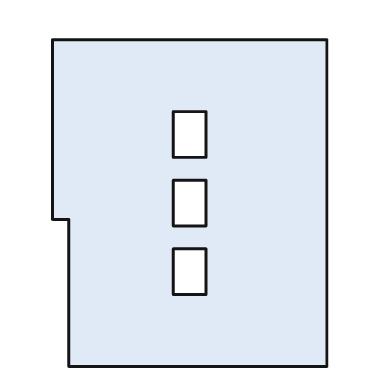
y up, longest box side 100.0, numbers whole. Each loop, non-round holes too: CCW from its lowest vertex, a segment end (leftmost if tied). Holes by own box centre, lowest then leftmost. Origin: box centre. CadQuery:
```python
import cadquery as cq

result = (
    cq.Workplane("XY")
    .moveTo(-37.0, -50.0)
    .lineTo(42.0, -50.0)
    .lineTo(42.0, 50.0)
    .lineTo(-42.0, 50.0)
    .lineTo(-42.0, -5.0)
    .lineTo(-37.0, -5.0)
    .close()
    .moveTo(-5.0, -28.0)
    .lineTo(5.0, -28.0)
    .lineTo(5.0, -14.0)
    .lineTo(-5.0, -14.0)
    .close()
    .moveTo(-5.0, -7.0)
    .lineTo(5.0, -7.0)
    .lineTo(5.0, 7.0)
    .lineTo(-5.0, 7.0)
    .close()
    .moveTo(-5.0, 14.0)
    .lineTo(5.0, 14.0)
    .lineTo(5.0, 28.0)
    .lineTo(-5.0, 28.0)
    .close()
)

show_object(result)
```